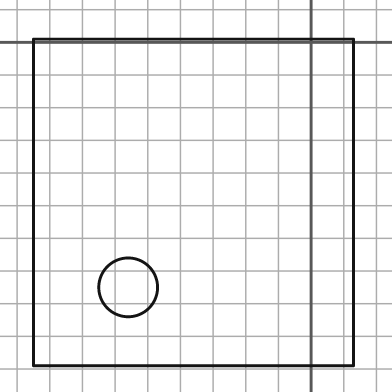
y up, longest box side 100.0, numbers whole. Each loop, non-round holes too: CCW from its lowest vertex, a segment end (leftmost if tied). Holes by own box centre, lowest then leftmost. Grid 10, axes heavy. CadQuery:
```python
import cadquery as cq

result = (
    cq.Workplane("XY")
    .moveTo(-85.0, -99.0)
    .lineTo(13.0, -99.0)
    .lineTo(13.0, 1.0)
    .lineTo(-85.0, 1.0)
    .close()
    .moveTo(-56.0, -75.0)
    .circle(9.0)
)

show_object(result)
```